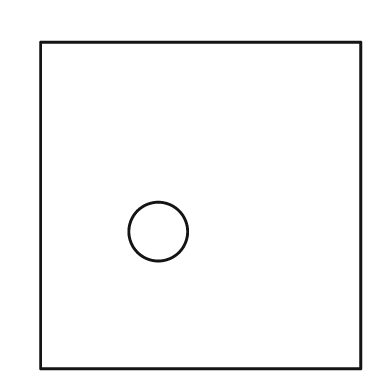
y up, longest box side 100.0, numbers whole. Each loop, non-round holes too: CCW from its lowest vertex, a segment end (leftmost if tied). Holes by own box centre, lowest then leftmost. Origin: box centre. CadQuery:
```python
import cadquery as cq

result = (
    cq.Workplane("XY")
    .moveTo(-49.0, -50.0)
    .lineTo(49.0, -50.0)
    .lineTo(49.0, 50.0)
    .lineTo(-49.0, 50.0)
    .close()
    .moveTo(-13.0, -8.0)
    .circle(9.0)
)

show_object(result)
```